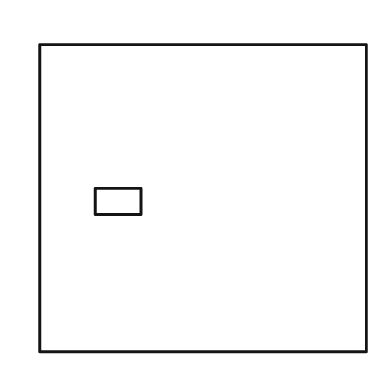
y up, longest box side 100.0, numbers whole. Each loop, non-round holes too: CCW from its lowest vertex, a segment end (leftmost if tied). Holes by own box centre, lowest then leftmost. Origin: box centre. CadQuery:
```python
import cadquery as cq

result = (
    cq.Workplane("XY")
    .moveTo(-50.0, -47.0)
    .lineTo(50.0, -47.0)
    .lineTo(50.0, 47.0)
    .lineTo(-50.0, 47.0)
    .close()
    .moveTo(-33.0, -5.0)
    .lineTo(-19.0, -5.0)
    .lineTo(-19.0, 3.0)
    .lineTo(-33.0, 3.0)
    .close()
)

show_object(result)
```